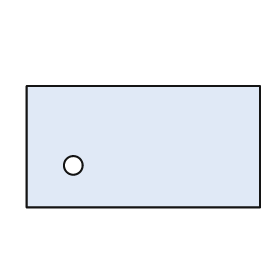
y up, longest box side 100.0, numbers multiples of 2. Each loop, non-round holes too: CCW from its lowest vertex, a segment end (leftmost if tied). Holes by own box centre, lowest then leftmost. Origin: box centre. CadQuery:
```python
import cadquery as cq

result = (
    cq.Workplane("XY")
    .moveTo(-50.0, -26.0)
    .lineTo(50.0, -26.0)
    .lineTo(50.0, 26.0)
    .lineTo(-50.0, 26.0)
    .close()
    .moveTo(-30.0, -8.0)
    .circle(4.0)
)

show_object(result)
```